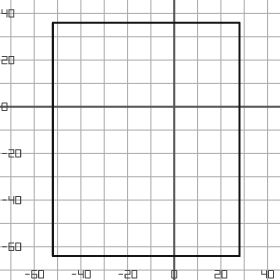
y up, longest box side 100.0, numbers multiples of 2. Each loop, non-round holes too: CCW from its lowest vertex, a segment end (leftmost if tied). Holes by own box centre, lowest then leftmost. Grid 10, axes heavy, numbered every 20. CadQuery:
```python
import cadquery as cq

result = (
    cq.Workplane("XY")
    .moveTo(-52.0, -64.0)
    .lineTo(28.0, -64.0)
    .lineTo(28.0, 36.0)
    .lineTo(-52.0, 36.0)
    .close()
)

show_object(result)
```